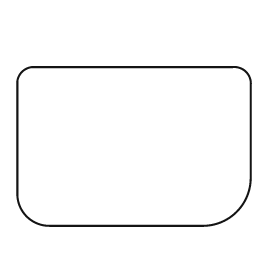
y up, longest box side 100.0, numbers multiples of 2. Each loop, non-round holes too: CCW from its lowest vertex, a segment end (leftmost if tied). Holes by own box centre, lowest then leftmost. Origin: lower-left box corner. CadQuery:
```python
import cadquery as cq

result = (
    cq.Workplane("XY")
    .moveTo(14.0, 0.0)
    .lineTo(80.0, 0.0)
    .threePointArc((94.0, 6.0), (100.0, 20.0))
    .lineTo(100.0, 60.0)
    .threePointArc((98.0, 66.0), (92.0, 68.0))
    .lineTo(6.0, 68.0)
    .threePointArc((2.0, 66.0), (0.0, 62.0))
    .lineTo(0.0, 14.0)
    .threePointArc((4.0, 4.0), (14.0, 0.0))
    .close()
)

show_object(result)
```